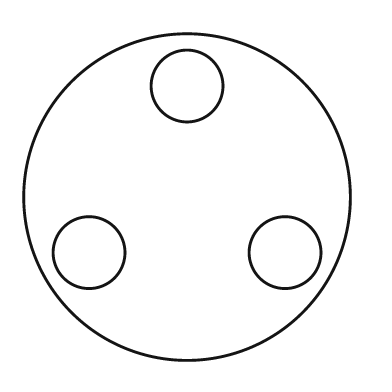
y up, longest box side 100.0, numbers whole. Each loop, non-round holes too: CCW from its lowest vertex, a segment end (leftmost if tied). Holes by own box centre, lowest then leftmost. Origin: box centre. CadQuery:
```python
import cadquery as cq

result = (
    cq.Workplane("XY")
    .moveTo(0.0, 0.0)
    .circle(50.0)
    .moveTo(-30.0, -17.0)
    .circle(11.0)
    .moveTo(30.0, -17.0)
    .circle(11.0)
    .moveTo(0.0, 34.0)
    .circle(11.0)
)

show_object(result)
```